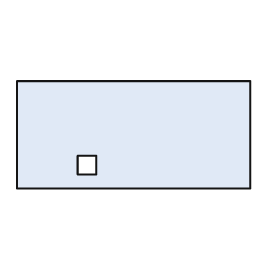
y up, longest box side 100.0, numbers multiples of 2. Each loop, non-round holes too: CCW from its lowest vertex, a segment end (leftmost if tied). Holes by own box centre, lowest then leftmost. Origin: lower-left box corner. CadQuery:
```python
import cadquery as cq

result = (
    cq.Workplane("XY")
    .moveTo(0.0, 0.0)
    .lineTo(100.0, 0.0)
    .lineTo(100.0, 46.0)
    .lineTo(0.0, 46.0)
    .close()
    .moveTo(26.0, 6.0)
    .lineTo(34.0, 6.0)
    .lineTo(34.0, 14.0)
    .lineTo(26.0, 14.0)
    .close()
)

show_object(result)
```